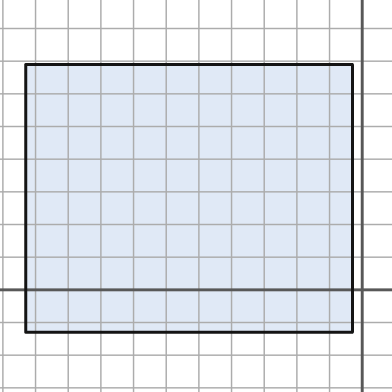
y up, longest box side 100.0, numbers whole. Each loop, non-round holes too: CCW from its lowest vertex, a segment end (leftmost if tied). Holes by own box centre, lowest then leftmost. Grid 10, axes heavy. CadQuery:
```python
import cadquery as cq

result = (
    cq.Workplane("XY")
    .moveTo(-103.0, -13.0)
    .lineTo(-3.0, -13.0)
    .lineTo(-3.0, 69.0)
    .lineTo(-103.0, 69.0)
    .close()
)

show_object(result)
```